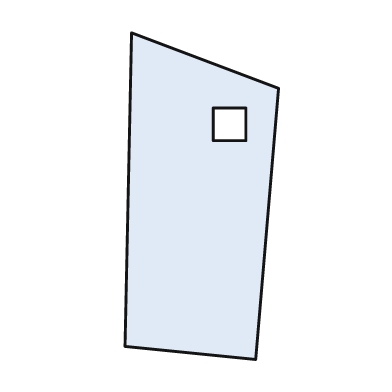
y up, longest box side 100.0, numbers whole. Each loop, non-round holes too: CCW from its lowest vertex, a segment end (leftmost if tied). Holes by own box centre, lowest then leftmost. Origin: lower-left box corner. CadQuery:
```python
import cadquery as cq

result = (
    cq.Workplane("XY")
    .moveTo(40.0, 0.0)
    .lineTo(47.0, 83.0)
    .lineTo(2.0, 100.0)
    .lineTo(0.0, 4.0)
    .close()
    .moveTo(27.0, 67.0)
    .lineTo(37.0, 67.0)
    .lineTo(37.0, 77.0)
    .lineTo(27.0, 77.0)
    .close()
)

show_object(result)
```